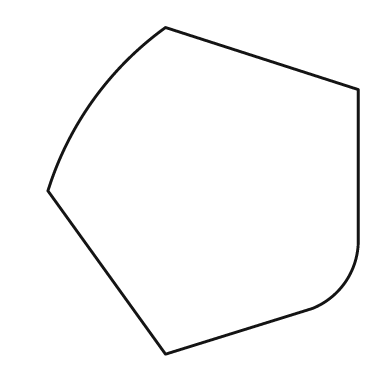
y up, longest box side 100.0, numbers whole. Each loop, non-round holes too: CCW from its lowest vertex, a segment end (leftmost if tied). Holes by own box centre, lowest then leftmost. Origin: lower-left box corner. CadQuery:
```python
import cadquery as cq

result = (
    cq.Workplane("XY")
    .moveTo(36.0, 0.0)
    .lineTo(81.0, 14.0)
    .threePointArc((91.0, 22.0), (95.0, 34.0))
    .lineTo(95.0, 81.0)
    .lineTo(36.0, 100.0)
    .threePointArc((14.0, 78.0), (0.0, 50.0))
    .close()
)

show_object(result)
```